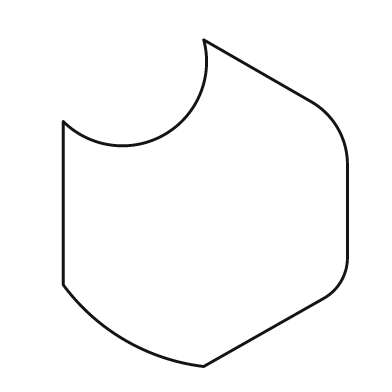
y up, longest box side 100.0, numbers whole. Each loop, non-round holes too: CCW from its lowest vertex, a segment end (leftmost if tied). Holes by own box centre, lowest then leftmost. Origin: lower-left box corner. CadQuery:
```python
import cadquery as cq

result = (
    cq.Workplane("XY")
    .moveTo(43.0, 0.0)
    .lineTo(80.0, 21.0)
    .threePointArc((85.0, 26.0), (87.0, 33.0))
    .lineTo(87.0, 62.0)
    .threePointArc((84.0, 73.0), (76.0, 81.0))
    .lineTo(43.0, 100.0)
    .threePointArc((31.0, 71.0), (0.0, 75.0))
    .lineTo(0.0, 25.0)
    .threePointArc((19.0, 8.0), (43.0, 0.0))
    .close()
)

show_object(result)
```